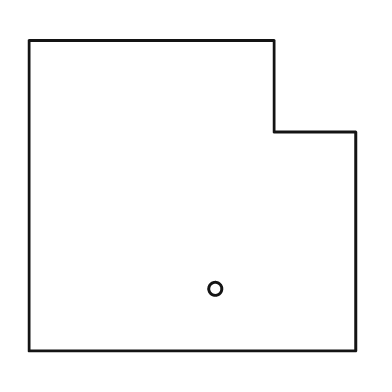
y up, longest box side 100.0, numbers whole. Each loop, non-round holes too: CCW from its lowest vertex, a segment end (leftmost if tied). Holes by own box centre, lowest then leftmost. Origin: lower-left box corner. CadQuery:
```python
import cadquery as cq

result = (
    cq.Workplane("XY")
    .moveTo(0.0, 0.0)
    .lineTo(100.0, 0.0)
    .lineTo(100.0, 67.0)
    .lineTo(75.0, 67.0)
    .lineTo(75.0, 95.0)
    .lineTo(0.0, 95.0)
    .close()
    .moveTo(57.0, 19.0)
    .circle(2.0)
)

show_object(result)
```